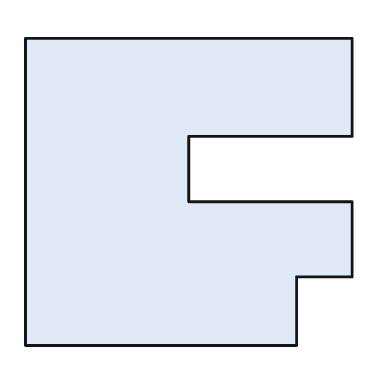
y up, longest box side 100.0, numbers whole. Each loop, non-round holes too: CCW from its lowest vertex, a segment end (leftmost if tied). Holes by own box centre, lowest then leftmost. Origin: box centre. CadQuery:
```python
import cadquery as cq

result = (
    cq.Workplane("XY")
    .moveTo(-50.0, -47.0)
    .lineTo(33.0, -47.0)
    .lineTo(33.0, -26.0)
    .lineTo(50.0, -26.0)
    .lineTo(50.0, -3.0)
    .lineTo(0.0, -3.0)
    .lineTo(0.0, 17.0)
    .lineTo(50.0, 17.0)
    .lineTo(50.0, 47.0)
    .lineTo(-50.0, 47.0)
    .close()
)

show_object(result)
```